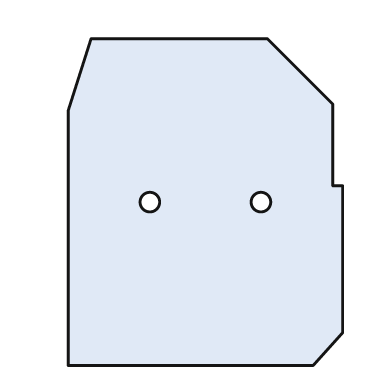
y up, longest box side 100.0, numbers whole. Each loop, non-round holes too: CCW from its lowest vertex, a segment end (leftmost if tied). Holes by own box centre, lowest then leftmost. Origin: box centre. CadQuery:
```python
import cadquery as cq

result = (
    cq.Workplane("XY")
    .moveTo(-42.0, -50.0)
    .lineTo(33.0, -50.0)
    .lineTo(42.0, -40.0)
    .lineTo(42.0, 5.0)
    .lineTo(39.0, 5.0)
    .lineTo(39.0, 30.0)
    .lineTo(19.0, 50.0)
    .lineTo(-35.0, 50.0)
    .lineTo(-42.0, 28.0)
    .close()
    .moveTo(-17.0, 0.0)
    .circle(3.0)
    .moveTo(17.0, 0.0)
    .circle(3.0)
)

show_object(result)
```